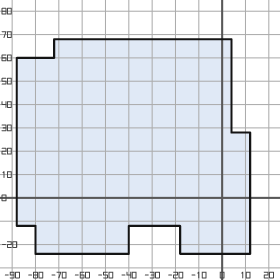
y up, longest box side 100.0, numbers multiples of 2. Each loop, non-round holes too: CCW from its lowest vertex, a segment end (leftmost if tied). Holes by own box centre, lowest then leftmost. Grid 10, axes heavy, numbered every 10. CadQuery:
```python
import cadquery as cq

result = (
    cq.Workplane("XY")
    .moveTo(-80.0, -24.0)
    .lineTo(-40.0, -24.0)
    .lineTo(-40.0, -12.0)
    .lineTo(-18.0, -12.0)
    .lineTo(-18.0, -24.0)
    .lineTo(12.0, -24.0)
    .lineTo(12.0, 28.0)
    .lineTo(4.0, 28.0)
    .lineTo(4.0, 68.0)
    .lineTo(-72.0, 68.0)
    .lineTo(-72.0, 60.0)
    .lineTo(-88.0, 60.0)
    .lineTo(-88.0, -12.0)
    .lineTo(-80.0, -12.0)
    .close()
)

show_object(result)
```